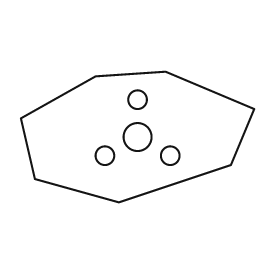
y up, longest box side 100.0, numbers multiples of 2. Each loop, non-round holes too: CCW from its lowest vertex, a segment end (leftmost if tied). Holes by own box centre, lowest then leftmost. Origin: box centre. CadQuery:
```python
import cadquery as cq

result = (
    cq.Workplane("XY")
    .moveTo(-8.0, -28.0)
    .lineTo(40.0, -12.0)
    .lineTo(50.0, 12.0)
    .lineTo(12.0, 28.0)
    .lineTo(-18.0, 26.0)
    .lineTo(-50.0, 8.0)
    .lineTo(-44.0, -18.0)
    .close()
    .moveTo(-14.0, -8.0)
    .circle(4.0)
    .moveTo(14.0, -8.0)
    .circle(4.0)
    .moveTo(0.0, 0.0)
    .circle(6.0)
    .moveTo(0.0, 16.0)
    .circle(4.0)
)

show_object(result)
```